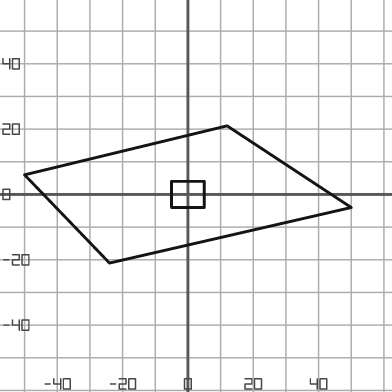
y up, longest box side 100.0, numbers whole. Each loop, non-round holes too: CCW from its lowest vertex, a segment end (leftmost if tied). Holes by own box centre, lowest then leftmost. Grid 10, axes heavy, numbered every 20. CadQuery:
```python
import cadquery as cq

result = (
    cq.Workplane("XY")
    .moveTo(-24.0, -21.0)
    .lineTo(50.0, -4.0)
    .lineTo(12.0, 21.0)
    .lineTo(-50.0, 6.0)
    .close()
    .moveTo(-5.0, -4.0)
    .lineTo(5.0, -4.0)
    .lineTo(5.0, 4.0)
    .lineTo(-5.0, 4.0)
    .close()
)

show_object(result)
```